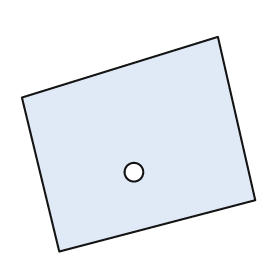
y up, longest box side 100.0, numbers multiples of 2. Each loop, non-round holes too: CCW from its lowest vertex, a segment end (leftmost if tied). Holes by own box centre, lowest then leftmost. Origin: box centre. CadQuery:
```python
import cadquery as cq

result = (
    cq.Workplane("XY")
    .moveTo(-34.0, -46.0)
    .lineTo(50.0, -24.0)
    .lineTo(34.0, 46.0)
    .lineTo(-50.0, 20.0)
    .close()
    .moveTo(-2.0, -12.0)
    .circle(4.0)
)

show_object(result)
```